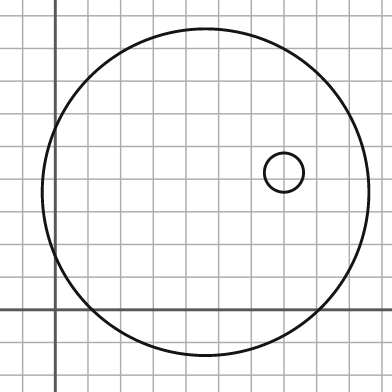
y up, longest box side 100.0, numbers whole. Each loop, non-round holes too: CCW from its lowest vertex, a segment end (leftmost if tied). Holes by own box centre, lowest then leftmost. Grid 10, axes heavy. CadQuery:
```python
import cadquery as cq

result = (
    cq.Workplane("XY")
    .moveTo(46.0, 36.0)
    .circle(50.0)
    .moveTo(70.0, 42.0)
    .circle(6.0)
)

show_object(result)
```